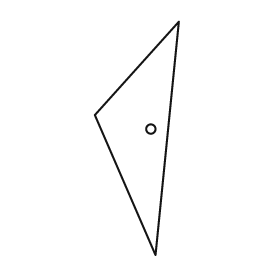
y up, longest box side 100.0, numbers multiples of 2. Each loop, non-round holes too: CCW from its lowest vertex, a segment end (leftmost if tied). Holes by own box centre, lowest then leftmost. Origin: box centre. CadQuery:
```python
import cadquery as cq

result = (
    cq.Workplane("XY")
    .moveTo(8.0, -50.0)
    .lineTo(18.0, 50.0)
    .lineTo(-18.0, 10.0)
    .close()
    .moveTo(6.0, 4.0)
    .circle(2.0)
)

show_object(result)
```